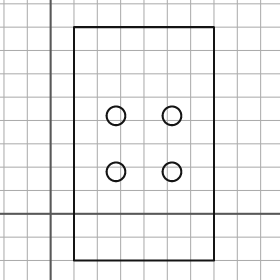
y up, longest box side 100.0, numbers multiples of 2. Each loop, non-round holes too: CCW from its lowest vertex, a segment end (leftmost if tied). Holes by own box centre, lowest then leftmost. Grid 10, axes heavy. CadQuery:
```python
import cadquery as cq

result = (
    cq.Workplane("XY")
    .moveTo(10.0, -20.0)
    .lineTo(70.0, -20.0)
    .lineTo(70.0, 80.0)
    .lineTo(10.0, 80.0)
    .close()
    .moveTo(28.0, 18.0)
    .circle(4.0)
    .moveTo(52.0, 18.0)
    .circle(4.0)
    .moveTo(28.0, 42.0)
    .circle(4.0)
    .moveTo(52.0, 42.0)
    .circle(4.0)
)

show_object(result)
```